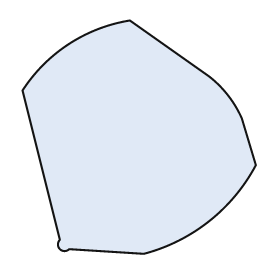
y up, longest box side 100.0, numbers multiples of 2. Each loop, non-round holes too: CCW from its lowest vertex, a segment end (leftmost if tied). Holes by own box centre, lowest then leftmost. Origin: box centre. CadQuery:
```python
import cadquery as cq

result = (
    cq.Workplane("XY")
    .moveTo(2.0, -50.0)
    .threePointArc((30.0, -36.0), (50.0, -12.0))
    .lineTo(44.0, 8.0)
    .threePointArc((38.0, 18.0), (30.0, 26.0))
    .lineTo(-4.0, 50.0)
    .threePointArc((-30.0, 40.0), (-50.0, 20.0))
    .lineTo(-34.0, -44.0)
    .threePointArc((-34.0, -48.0), (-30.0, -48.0))
    .close()
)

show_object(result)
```